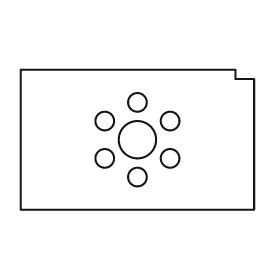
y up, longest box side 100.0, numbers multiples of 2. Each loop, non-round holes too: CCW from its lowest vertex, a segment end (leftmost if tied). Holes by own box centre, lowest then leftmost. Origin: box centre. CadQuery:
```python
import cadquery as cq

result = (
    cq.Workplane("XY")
    .moveTo(-50.0, -30.0)
    .lineTo(50.0, -30.0)
    .lineTo(50.0, 26.0)
    .lineTo(42.0, 26.0)
    .lineTo(42.0, 30.0)
    .lineTo(-50.0, 30.0)
    .close()
    .moveTo(0.0, -16.0)
    .circle(4.0)
    .moveTo(-14.0, -8.0)
    .circle(4.0)
    .moveTo(14.0, -8.0)
    .circle(4.0)
    .moveTo(0.0, 0.0)
    .circle(8.0)
    .moveTo(-14.0, 8.0)
    .circle(4.0)
    .moveTo(14.0, 8.0)
    .circle(4.0)
    .moveTo(0.0, 16.0)
    .circle(4.0)
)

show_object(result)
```